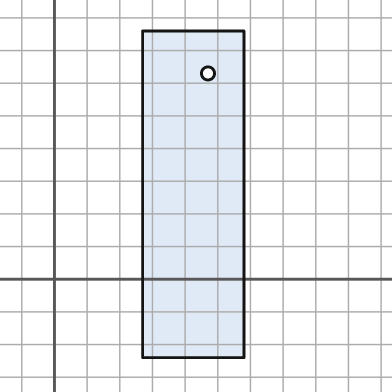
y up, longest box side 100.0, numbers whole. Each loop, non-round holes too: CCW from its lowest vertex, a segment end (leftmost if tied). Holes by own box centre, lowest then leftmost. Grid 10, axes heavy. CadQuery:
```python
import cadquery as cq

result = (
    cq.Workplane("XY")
    .moveTo(27.0, -24.0)
    .lineTo(58.0, -24.0)
    .lineTo(58.0, 76.0)
    .lineTo(27.0, 76.0)
    .close()
    .moveTo(47.0, 63.0)
    .circle(2.0)
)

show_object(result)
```